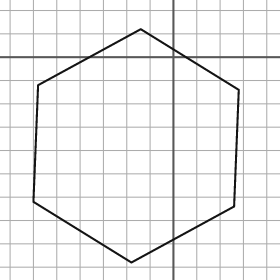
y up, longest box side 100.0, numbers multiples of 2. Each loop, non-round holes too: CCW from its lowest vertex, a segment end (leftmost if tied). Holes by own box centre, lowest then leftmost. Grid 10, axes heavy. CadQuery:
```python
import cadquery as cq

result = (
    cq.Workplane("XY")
    .moveTo(-18.0, -88.0)
    .lineTo(26.0, -64.0)
    .lineTo(28.0, -14.0)
    .lineTo(-14.0, 12.0)
    .lineTo(-58.0, -12.0)
    .lineTo(-60.0, -62.0)
    .close()
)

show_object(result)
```